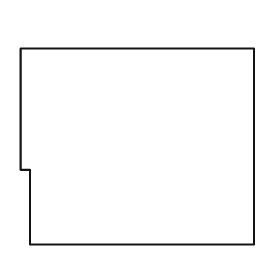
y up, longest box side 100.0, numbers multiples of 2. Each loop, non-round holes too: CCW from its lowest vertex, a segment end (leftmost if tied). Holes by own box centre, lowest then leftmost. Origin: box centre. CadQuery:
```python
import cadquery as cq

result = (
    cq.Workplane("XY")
    .moveTo(-46.0, -42.0)
    .lineTo(50.0, -42.0)
    .lineTo(50.0, 42.0)
    .lineTo(-50.0, 42.0)
    .lineTo(-50.0, -10.0)
    .lineTo(-46.0, -10.0)
    .close()
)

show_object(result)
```